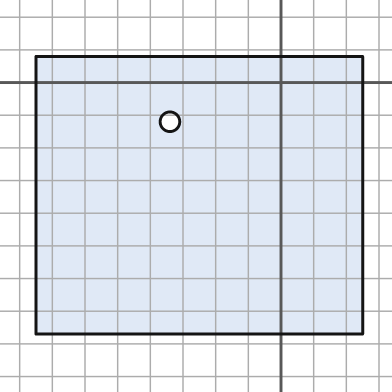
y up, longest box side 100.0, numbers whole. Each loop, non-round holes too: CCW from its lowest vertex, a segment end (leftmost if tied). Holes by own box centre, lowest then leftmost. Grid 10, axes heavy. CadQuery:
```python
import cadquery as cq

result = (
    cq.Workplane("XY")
    .moveTo(-75.0, -77.0)
    .lineTo(25.0, -77.0)
    .lineTo(25.0, 8.0)
    .lineTo(-75.0, 8.0)
    .close()
    .moveTo(-34.0, -12.0)
    .circle(3.0)
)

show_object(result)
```